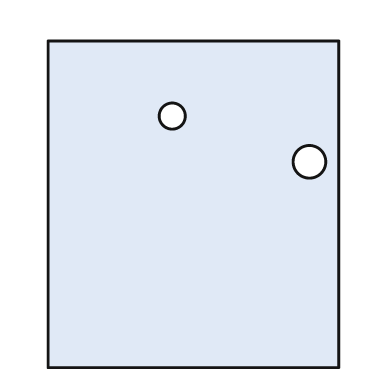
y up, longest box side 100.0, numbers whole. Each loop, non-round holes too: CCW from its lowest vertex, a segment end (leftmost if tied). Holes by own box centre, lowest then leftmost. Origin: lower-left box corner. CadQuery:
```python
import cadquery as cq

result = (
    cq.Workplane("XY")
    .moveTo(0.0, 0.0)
    .lineTo(89.0, 0.0)
    .lineTo(89.0, 100.0)
    .lineTo(0.0, 100.0)
    .close()
    .moveTo(80.0, 63.0)
    .circle(5.0)
    .moveTo(38.0, 77.0)
    .circle(4.0)
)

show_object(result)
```